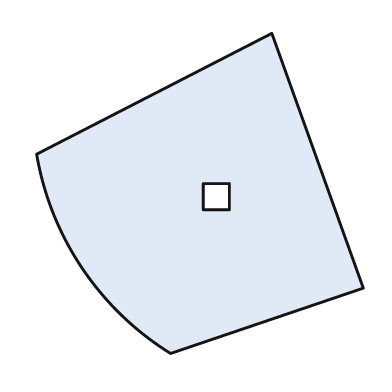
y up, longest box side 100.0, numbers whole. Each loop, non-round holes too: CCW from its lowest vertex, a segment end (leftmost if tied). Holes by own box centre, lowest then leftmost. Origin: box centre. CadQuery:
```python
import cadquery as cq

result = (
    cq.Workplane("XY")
    .moveTo(-9.0, -49.0)
    .lineTo(50.0, -29.0)
    .lineTo(22.0, 49.0)
    .lineTo(-50.0, 12.0)
    .threePointArc((-36.0, -23.0), (-9.0, -49.0))
    .close()
    .moveTo(1.0, -5.0)
    .lineTo(9.0, -5.0)
    .lineTo(9.0, 3.0)
    .lineTo(1.0, 3.0)
    .close()
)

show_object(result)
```